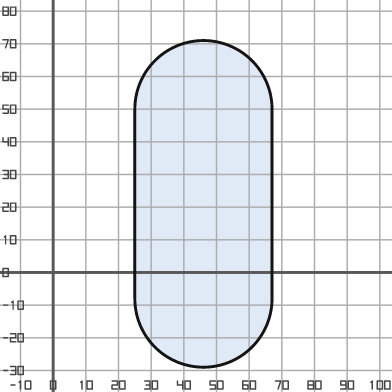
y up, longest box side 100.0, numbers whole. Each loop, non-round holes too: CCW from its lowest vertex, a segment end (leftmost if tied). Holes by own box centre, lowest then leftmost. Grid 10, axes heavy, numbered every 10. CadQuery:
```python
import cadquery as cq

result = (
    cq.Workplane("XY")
    .moveTo(25.0, -8.0)
    .threePointArc((46.0, -29.0), (67.0, -8.0))
    .lineTo(67.0, 50.0)
    .threePointArc((46.0, 71.0), (25.0, 50.0))
    .close()
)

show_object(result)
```